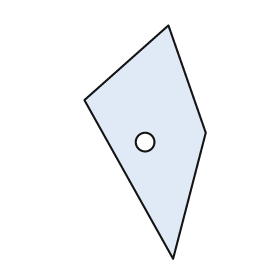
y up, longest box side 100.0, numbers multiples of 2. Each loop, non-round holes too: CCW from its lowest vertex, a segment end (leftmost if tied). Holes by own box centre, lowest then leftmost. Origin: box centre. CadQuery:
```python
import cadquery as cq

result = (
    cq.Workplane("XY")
    .moveTo(12.0, -50.0)
    .lineTo(26.0, 4.0)
    .lineTo(10.0, 50.0)
    .lineTo(-26.0, 18.0)
    .close()
    .moveTo(0.0, 0.0)
    .circle(4.0)
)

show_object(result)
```